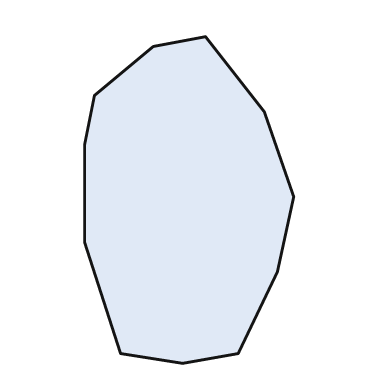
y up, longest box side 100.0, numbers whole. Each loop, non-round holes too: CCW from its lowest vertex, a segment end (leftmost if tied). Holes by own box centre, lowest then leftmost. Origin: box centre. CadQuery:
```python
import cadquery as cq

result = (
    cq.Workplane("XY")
    .moveTo(-2.0, -50.0)
    .lineTo(15.0, -47.0)
    .lineTo(27.0, -22.0)
    .lineTo(32.0, 1.0)
    .lineTo(23.0, 27.0)
    .lineTo(5.0, 50.0)
    .lineTo(-11.0, 47.0)
    .lineTo(-29.0, 32.0)
    .lineTo(-32.0, 17.0)
    .lineTo(-32.0, -13.0)
    .lineTo(-21.0, -47.0)
    .close()
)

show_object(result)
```